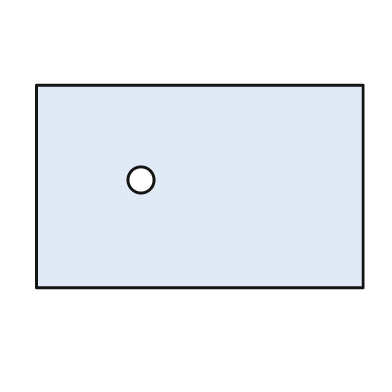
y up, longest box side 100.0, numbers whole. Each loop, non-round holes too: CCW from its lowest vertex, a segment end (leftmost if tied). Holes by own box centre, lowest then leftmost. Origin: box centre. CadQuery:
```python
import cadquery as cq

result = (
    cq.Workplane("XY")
    .moveTo(-50.0, -31.0)
    .lineTo(50.0, -31.0)
    .lineTo(50.0, 31.0)
    .lineTo(-50.0, 31.0)
    .close()
    .moveTo(-18.0, 2.0)
    .circle(4.0)
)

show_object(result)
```